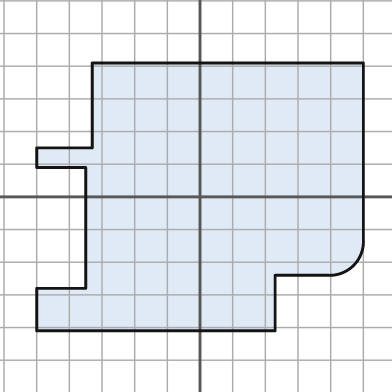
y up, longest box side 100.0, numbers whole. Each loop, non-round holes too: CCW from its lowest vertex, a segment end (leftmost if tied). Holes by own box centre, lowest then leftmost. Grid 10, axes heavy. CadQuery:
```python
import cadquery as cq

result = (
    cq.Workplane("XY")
    .moveTo(-50.0, -41.0)
    .lineTo(23.0, -41.0)
    .lineTo(23.0, -24.0)
    .lineTo(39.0, -24.0)
    .threePointArc((47.0, -21.0), (50.0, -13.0))
    .lineTo(50.0, 41.0)
    .lineTo(-33.0, 41.0)
    .lineTo(-33.0, 15.0)
    .lineTo(-50.0, 15.0)
    .lineTo(-50.0, 9.0)
    .lineTo(-35.0, 9.0)
    .lineTo(-35.0, -28.0)
    .lineTo(-50.0, -28.0)
    .close()
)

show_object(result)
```